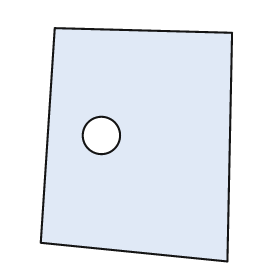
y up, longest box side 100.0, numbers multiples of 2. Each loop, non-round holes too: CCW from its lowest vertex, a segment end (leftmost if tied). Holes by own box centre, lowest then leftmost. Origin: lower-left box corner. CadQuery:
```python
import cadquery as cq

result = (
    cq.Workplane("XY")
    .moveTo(80.0, 0.0)
    .lineTo(82.0, 98.0)
    .lineTo(6.0, 100.0)
    .lineTo(0.0, 8.0)
    .close()
    .moveTo(26.0, 54.0)
    .circle(8.0)
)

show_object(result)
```